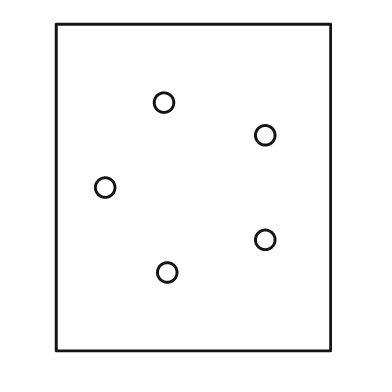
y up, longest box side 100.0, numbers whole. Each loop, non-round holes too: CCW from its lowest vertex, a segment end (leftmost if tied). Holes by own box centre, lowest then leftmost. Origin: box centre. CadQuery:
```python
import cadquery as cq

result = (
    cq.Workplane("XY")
    .moveTo(-42.0, -50.0)
    .lineTo(42.0, -50.0)
    .lineTo(42.0, 50.0)
    .lineTo(-42.0, 50.0)
    .close()
    .moveTo(-8.0, -26.0)
    .circle(3.0)
    .moveTo(22.0, -16.0)
    .circle(3.0)
    .moveTo(-27.0, 0.0)
    .circle(3.0)
    .moveTo(22.0, 16.0)
    .circle(3.0)
    .moveTo(-9.0, 26.0)
    .circle(3.0)
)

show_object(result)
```